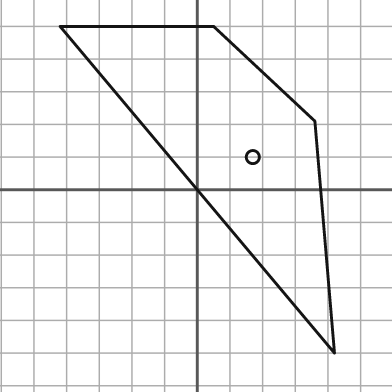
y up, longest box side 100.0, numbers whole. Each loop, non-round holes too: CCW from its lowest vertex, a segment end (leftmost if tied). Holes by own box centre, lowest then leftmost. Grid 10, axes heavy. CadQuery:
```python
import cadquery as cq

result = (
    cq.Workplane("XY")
    .moveTo(42.0, -50.0)
    .lineTo(36.0, 21.0)
    .lineTo(5.0, 50.0)
    .lineTo(-42.0, 50.0)
    .close()
    .moveTo(17.0, 10.0)
    .circle(2.0)
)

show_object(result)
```